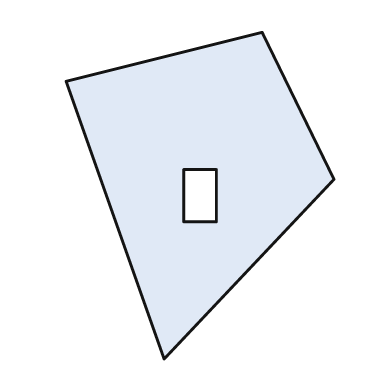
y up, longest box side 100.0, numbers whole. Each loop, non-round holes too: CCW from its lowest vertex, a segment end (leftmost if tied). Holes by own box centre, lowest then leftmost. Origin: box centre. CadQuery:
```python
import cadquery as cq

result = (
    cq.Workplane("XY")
    .moveTo(-11.0, -50.0)
    .lineTo(41.0, 5.0)
    .lineTo(19.0, 50.0)
    .lineTo(-41.0, 35.0)
    .close()
    .moveTo(-5.0, -8.0)
    .lineTo(5.0, -8.0)
    .lineTo(5.0, 8.0)
    .lineTo(-5.0, 8.0)
    .close()
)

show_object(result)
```